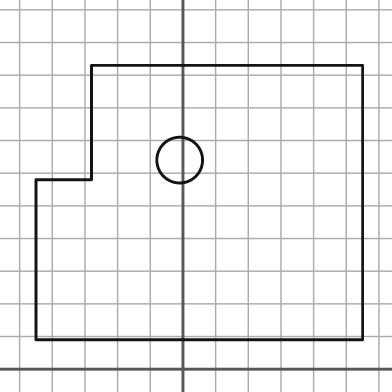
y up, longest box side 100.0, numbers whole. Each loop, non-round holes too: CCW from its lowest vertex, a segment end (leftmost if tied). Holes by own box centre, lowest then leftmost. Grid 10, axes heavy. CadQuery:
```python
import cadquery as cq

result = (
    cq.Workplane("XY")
    .moveTo(-45.0, 9.0)
    .lineTo(55.0, 9.0)
    .lineTo(55.0, 93.0)
    .lineTo(-28.0, 93.0)
    .lineTo(-28.0, 58.0)
    .lineTo(-45.0, 58.0)
    .close()
    .moveTo(-1.0, 64.0)
    .circle(7.0)
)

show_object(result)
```